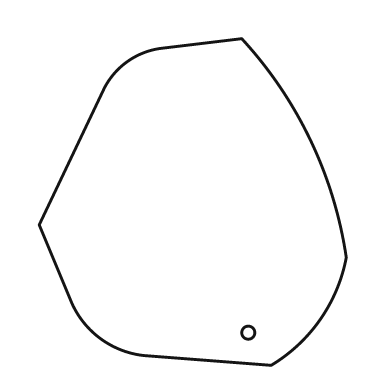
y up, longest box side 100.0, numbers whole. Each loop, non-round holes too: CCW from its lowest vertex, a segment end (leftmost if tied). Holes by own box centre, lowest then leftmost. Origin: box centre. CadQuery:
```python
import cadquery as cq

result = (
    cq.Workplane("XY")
    .moveTo(24.0, -50.0)
    .threePointArc((39.0, -36.0), (47.0, -17.0))
    .threePointArc((36.0, 19.0), (15.0, 50.0))
    .lineTo(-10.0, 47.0)
    .threePointArc((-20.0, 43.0), (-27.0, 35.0))
    .lineTo(-47.0, -7.0)
    .lineTo(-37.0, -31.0)
    .threePointArc((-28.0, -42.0), (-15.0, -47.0))
    .close()
    .moveTo(17.0, -40.0)
    .circle(2.0)
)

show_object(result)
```